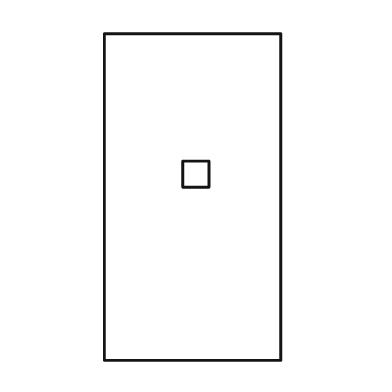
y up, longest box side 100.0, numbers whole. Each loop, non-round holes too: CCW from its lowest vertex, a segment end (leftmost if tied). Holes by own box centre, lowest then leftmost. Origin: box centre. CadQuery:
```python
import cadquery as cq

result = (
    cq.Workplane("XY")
    .moveTo(-27.0, -50.0)
    .lineTo(27.0, -50.0)
    .lineTo(27.0, 50.0)
    .lineTo(-27.0, 50.0)
    .close()
    .moveTo(-3.0, 3.0)
    .lineTo(5.0, 3.0)
    .lineTo(5.0, 11.0)
    .lineTo(-3.0, 11.0)
    .close()
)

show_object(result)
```